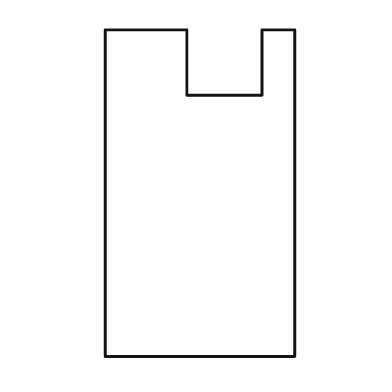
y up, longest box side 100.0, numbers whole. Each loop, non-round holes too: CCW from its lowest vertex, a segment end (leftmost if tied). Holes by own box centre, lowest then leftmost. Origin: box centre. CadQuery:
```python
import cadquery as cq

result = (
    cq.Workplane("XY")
    .moveTo(-29.0, -50.0)
    .lineTo(29.0, -50.0)
    .lineTo(29.0, 50.0)
    .lineTo(19.0, 50.0)
    .lineTo(19.0, 30.0)
    .lineTo(-4.0, 30.0)
    .lineTo(-4.0, 50.0)
    .lineTo(-29.0, 50.0)
    .close()
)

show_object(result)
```